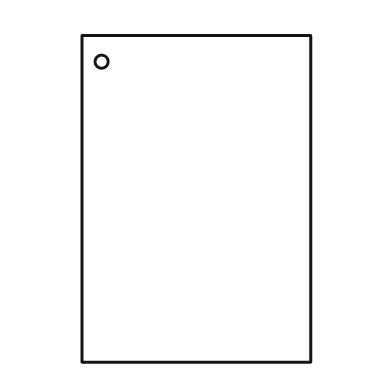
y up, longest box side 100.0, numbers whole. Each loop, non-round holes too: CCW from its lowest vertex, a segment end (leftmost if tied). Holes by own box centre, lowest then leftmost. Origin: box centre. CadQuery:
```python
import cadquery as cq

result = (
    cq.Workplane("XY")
    .moveTo(-35.0, -50.0)
    .lineTo(35.0, -50.0)
    .lineTo(35.0, 50.0)
    .lineTo(-35.0, 50.0)
    .close()
    .moveTo(-29.0, 42.0)
    .circle(2.0)
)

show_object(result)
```